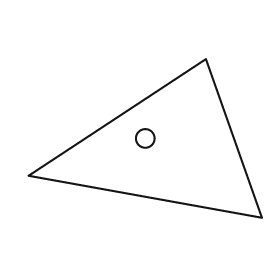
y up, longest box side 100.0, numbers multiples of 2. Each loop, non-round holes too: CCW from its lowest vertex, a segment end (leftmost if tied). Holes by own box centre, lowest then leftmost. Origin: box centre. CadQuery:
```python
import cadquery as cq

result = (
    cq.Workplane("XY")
    .moveTo(50.0, -34.0)
    .lineTo(26.0, 34.0)
    .lineTo(-50.0, -16.0)
    .close()
    .moveTo(0.0, 0.0)
    .circle(4.0)
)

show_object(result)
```